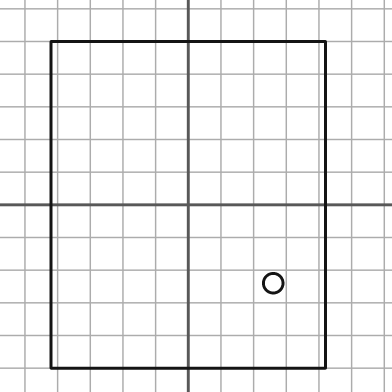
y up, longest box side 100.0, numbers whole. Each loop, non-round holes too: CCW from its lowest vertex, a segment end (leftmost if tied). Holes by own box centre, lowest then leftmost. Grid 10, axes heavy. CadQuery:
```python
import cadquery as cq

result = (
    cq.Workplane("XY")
    .moveTo(-42.0, -50.0)
    .lineTo(42.0, -50.0)
    .lineTo(42.0, 50.0)
    .lineTo(-42.0, 50.0)
    .close()
    .moveTo(26.0, -24.0)
    .circle(3.0)
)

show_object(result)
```